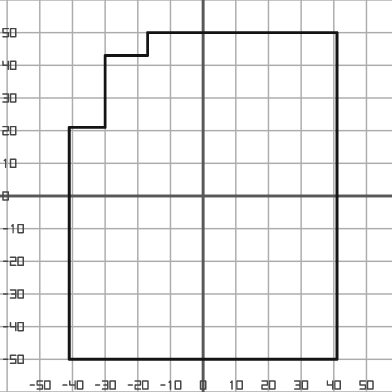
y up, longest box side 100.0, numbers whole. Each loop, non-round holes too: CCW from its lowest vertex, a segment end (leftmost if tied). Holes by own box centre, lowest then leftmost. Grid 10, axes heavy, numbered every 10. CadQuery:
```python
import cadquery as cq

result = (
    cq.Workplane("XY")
    .moveTo(-41.0, -50.0)
    .lineTo(41.0, -50.0)
    .lineTo(41.0, 50.0)
    .lineTo(-17.0, 50.0)
    .lineTo(-17.0, 43.0)
    .lineTo(-30.0, 43.0)
    .lineTo(-30.0, 21.0)
    .lineTo(-41.0, 21.0)
    .close()
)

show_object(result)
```